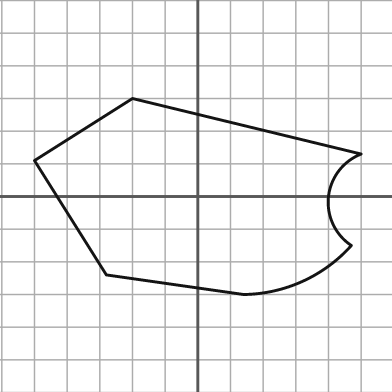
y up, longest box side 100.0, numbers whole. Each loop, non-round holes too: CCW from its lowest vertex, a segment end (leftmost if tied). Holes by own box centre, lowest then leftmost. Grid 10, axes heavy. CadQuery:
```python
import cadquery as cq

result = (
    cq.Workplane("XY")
    .moveTo(14.0, -30.0)
    .threePointArc((32.0, -26.0), (47.0, -15.0))
    .threePointArc((40.0, 0.0), (50.0, 13.0))
    .lineTo(-20.0, 30.0)
    .lineTo(-50.0, 11.0)
    .lineTo(-28.0, -24.0)
    .close()
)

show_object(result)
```